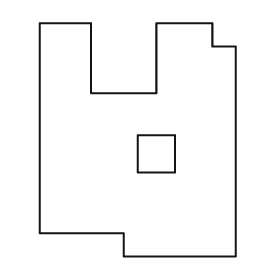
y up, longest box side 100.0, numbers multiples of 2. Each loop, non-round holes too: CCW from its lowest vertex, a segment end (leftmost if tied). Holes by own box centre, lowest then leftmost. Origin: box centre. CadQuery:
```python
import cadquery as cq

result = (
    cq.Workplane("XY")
    .moveTo(-6.0, -50.0)
    .lineTo(42.0, -50.0)
    .lineTo(42.0, 40.0)
    .lineTo(32.0, 40.0)
    .lineTo(32.0, 50.0)
    .lineTo(8.0, 50.0)
    .lineTo(8.0, 20.0)
    .lineTo(-20.0, 20.0)
    .lineTo(-20.0, 50.0)
    .lineTo(-42.0, 50.0)
    .lineTo(-42.0, -40.0)
    .lineTo(-6.0, -40.0)
    .close()
    .moveTo(0.0, -14.0)
    .lineTo(16.0, -14.0)
    .lineTo(16.0, 2.0)
    .lineTo(0.0, 2.0)
    .close()
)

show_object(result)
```